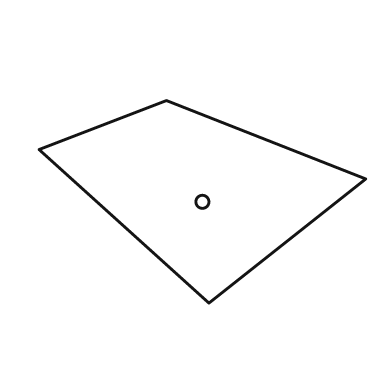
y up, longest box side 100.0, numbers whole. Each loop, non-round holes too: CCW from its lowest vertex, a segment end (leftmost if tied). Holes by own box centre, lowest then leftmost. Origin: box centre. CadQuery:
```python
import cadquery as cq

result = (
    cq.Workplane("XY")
    .moveTo(2.0, -31.0)
    .lineTo(50.0, 7.0)
    .lineTo(-11.0, 31.0)
    .lineTo(-50.0, 16.0)
    .close()
    .moveTo(0.0, 0.0)
    .circle(2.0)
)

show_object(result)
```